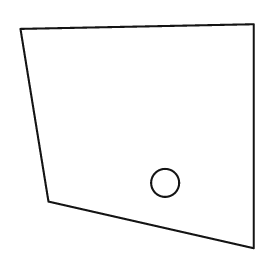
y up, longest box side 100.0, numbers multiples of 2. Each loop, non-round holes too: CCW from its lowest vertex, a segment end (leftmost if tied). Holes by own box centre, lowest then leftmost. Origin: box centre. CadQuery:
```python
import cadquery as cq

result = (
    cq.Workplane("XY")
    .moveTo(50.0, -48.0)
    .lineTo(50.0, 48.0)
    .lineTo(-50.0, 46.0)
    .lineTo(-38.0, -28.0)
    .close()
    .moveTo(12.0, -20.0)
    .circle(6.0)
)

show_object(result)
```